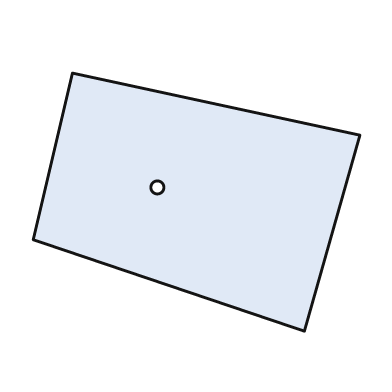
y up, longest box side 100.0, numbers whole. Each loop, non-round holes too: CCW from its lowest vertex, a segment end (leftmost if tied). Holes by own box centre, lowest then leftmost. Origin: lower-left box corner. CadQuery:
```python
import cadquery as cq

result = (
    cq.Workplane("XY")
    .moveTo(83.0, 0.0)
    .lineTo(100.0, 60.0)
    .lineTo(12.0, 79.0)
    .lineTo(0.0, 28.0)
    .close()
    .moveTo(38.0, 44.0)
    .circle(2.0)
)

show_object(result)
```